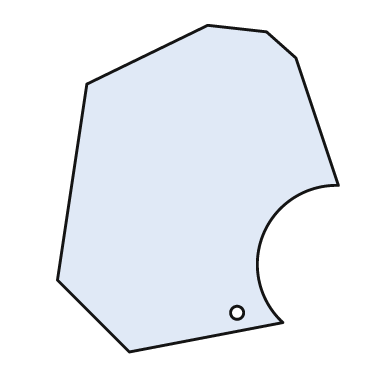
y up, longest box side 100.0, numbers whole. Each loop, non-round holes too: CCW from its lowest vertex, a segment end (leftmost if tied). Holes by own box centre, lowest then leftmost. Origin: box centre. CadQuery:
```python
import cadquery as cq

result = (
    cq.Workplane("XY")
    .moveTo(-21.0, -50.0)
    .lineTo(26.0, -41.0)
    .threePointArc((20.0, -14.0), (43.0, 1.0))
    .lineTo(30.0, 40.0)
    .lineTo(21.0, 48.0)
    .lineTo(3.0, 50.0)
    .lineTo(-34.0, 32.0)
    .lineTo(-43.0, -28.0)
    .close()
    .moveTo(12.0, -38.0)
    .circle(2.0)
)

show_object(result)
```